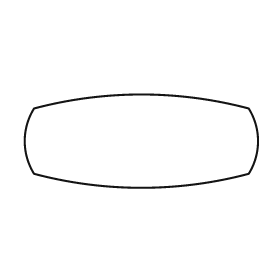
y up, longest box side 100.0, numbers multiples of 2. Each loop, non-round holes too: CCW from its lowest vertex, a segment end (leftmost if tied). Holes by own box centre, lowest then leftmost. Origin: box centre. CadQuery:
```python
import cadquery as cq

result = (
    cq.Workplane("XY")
    .moveTo(-46.0, -14.0)
    .threePointArc((0.0, -20.0), (46.0, -14.0))
    .threePointArc((50.0, 0.0), (46.0, 14.0))
    .threePointArc((0.0, 20.0), (-46.0, 14.0))
    .threePointArc((-50.0, 0.0), (-46.0, -14.0))
    .close()
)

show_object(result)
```